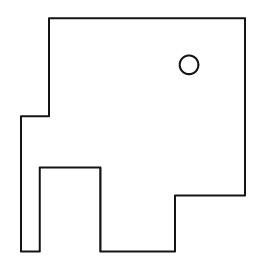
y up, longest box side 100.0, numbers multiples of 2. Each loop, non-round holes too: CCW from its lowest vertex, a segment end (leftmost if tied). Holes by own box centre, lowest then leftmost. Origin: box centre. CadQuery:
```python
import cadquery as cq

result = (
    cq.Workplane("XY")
    .moveTo(-48.0, -50.0)
    .lineTo(-40.0, -50.0)
    .lineTo(-40.0, -14.0)
    .lineTo(-14.0, -14.0)
    .lineTo(-14.0, -50.0)
    .lineTo(18.0, -50.0)
    .lineTo(18.0, -26.0)
    .lineTo(48.0, -26.0)
    .lineTo(48.0, 50.0)
    .lineTo(-36.0, 50.0)
    .lineTo(-36.0, 8.0)
    .lineTo(-48.0, 8.0)
    .close()
    .moveTo(24.0, 30.0)
    .circle(4.0)
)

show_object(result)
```